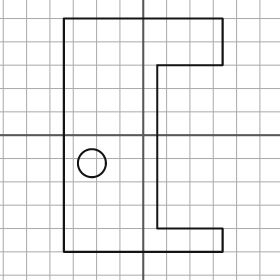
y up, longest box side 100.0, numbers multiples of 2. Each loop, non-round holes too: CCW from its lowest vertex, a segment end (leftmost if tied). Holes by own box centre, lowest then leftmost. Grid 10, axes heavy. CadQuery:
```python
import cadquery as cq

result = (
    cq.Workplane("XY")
    .moveTo(-34.0, -50.0)
    .lineTo(34.0, -50.0)
    .lineTo(34.0, -40.0)
    .lineTo(6.0, -40.0)
    .lineTo(6.0, 30.0)
    .lineTo(34.0, 30.0)
    .lineTo(34.0, 50.0)
    .lineTo(-34.0, 50.0)
    .close()
    .moveTo(-22.0, -12.0)
    .circle(6.0)
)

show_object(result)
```